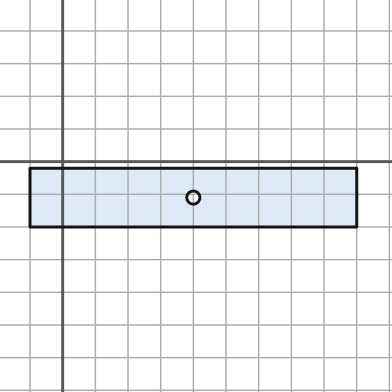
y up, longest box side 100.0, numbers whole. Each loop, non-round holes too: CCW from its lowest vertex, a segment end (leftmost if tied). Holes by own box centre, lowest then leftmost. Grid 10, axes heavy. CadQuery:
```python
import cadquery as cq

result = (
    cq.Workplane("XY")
    .moveTo(-10.0, -20.0)
    .lineTo(90.0, -20.0)
    .lineTo(90.0, -2.0)
    .lineTo(-10.0, -2.0)
    .close()
    .moveTo(40.0, -11.0)
    .circle(2.0)
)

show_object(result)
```